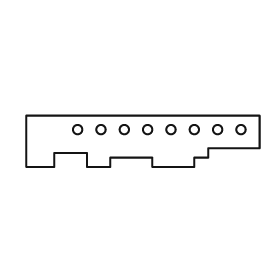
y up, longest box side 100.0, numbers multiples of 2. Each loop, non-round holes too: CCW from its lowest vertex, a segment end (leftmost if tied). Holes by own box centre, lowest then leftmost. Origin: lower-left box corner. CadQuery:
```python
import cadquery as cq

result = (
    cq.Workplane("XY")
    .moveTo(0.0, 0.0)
    .lineTo(12.0, 0.0)
    .lineTo(12.0, 6.0)
    .lineTo(26.0, 6.0)
    .lineTo(26.0, 0.0)
    .lineTo(36.0, 0.0)
    .lineTo(36.0, 4.0)
    .lineTo(54.0, 4.0)
    .lineTo(54.0, 0.0)
    .lineTo(72.0, 0.0)
    .lineTo(72.0, 4.0)
    .lineTo(78.0, 4.0)
    .lineTo(78.0, 8.0)
    .lineTo(100.0, 8.0)
    .lineTo(100.0, 22.0)
    .lineTo(0.0, 22.0)
    .close()
    .moveTo(22.0, 16.0)
    .circle(2.0)
    .moveTo(32.0, 16.0)
    .circle(2.0)
    .moveTo(42.0, 16.0)
    .circle(2.0)
    .moveTo(52.0, 16.0)
    .circle(2.0)
    .moveTo(62.0, 16.0)
    .circle(2.0)
    .moveTo(72.0, 16.0)
    .circle(2.0)
    .moveTo(82.0, 16.0)
    .circle(2.0)
    .moveTo(92.0, 16.0)
    .circle(2.0)
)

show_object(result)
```